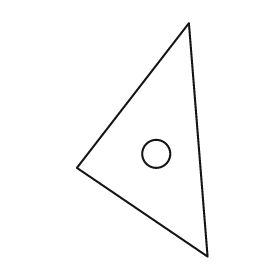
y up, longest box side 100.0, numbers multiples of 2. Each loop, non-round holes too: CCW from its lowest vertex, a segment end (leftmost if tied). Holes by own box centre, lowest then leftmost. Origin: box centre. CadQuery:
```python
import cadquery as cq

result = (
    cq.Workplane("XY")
    .moveTo(28.0, -50.0)
    .lineTo(20.0, 50.0)
    .lineTo(-28.0, -12.0)
    .close()
    .moveTo(6.0, -6.0)
    .circle(6.0)
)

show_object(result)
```